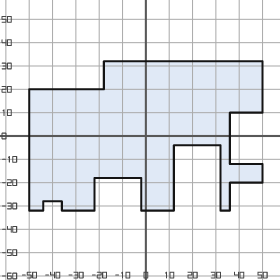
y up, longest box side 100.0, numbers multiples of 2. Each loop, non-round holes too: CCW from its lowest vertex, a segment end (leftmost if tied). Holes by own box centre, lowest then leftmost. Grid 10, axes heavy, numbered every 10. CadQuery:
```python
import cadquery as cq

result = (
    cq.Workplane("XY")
    .moveTo(-50.0, -32.0)
    .lineTo(-44.0, -32.0)
    .lineTo(-44.0, -28.0)
    .lineTo(-36.0, -28.0)
    .lineTo(-36.0, -32.0)
    .lineTo(-22.0, -32.0)
    .lineTo(-22.0, -18.0)
    .lineTo(-2.0, -18.0)
    .lineTo(-2.0, -32.0)
    .lineTo(12.0, -32.0)
    .lineTo(12.0, -4.0)
    .lineTo(32.0, -4.0)
    .lineTo(32.0, -32.0)
    .lineTo(36.0, -32.0)
    .lineTo(36.0, -20.0)
    .lineTo(50.0, -20.0)
    .lineTo(50.0, -12.0)
    .lineTo(36.0, -12.0)
    .lineTo(36.0, 10.0)
    .lineTo(50.0, 10.0)
    .lineTo(50.0, 32.0)
    .lineTo(-18.0, 32.0)
    .lineTo(-18.0, 20.0)
    .lineTo(-50.0, 20.0)
    .close()
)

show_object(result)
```